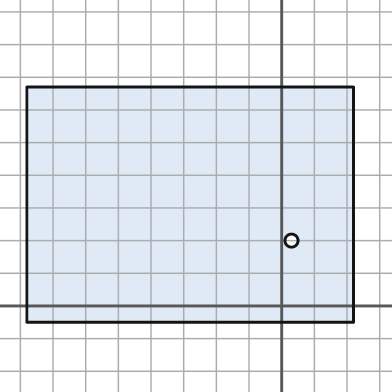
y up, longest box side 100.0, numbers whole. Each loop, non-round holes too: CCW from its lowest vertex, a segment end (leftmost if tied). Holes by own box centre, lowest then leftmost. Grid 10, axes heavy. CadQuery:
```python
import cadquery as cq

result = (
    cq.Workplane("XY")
    .moveTo(-78.0, -5.0)
    .lineTo(22.0, -5.0)
    .lineTo(22.0, 67.0)
    .lineTo(-78.0, 67.0)
    .close()
    .moveTo(3.0, 20.0)
    .circle(2.0)
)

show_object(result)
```